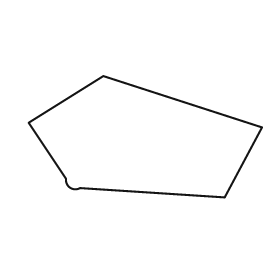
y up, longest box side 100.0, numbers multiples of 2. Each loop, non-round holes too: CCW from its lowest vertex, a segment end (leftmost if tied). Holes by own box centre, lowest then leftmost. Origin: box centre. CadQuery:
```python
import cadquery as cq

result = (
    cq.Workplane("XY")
    .moveTo(34.0, -26.0)
    .lineTo(50.0, 4.0)
    .lineTo(-18.0, 26.0)
    .lineTo(-50.0, 6.0)
    .lineTo(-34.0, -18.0)
    .threePointArc((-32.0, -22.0), (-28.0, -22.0))
    .close()
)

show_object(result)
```